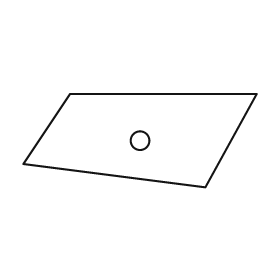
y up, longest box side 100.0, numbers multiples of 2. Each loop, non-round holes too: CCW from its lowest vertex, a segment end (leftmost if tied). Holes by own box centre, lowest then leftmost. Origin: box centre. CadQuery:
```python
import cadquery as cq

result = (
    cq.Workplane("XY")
    .moveTo(28.0, -20.0)
    .lineTo(50.0, 20.0)
    .lineTo(-30.0, 20.0)
    .lineTo(-50.0, -10.0)
    .close()
    .moveTo(0.0, 0.0)
    .circle(4.0)
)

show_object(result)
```